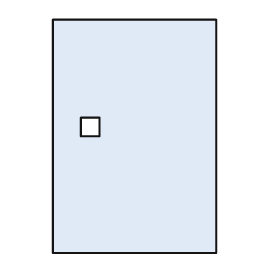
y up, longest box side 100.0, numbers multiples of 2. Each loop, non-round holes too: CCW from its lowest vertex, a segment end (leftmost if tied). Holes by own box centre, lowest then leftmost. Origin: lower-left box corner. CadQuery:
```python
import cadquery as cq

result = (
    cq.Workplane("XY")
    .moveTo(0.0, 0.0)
    .lineTo(70.0, 0.0)
    .lineTo(70.0, 100.0)
    .lineTo(0.0, 100.0)
    .close()
    .moveTo(12.0, 50.0)
    .lineTo(20.0, 50.0)
    .lineTo(20.0, 58.0)
    .lineTo(12.0, 58.0)
    .close()
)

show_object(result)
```